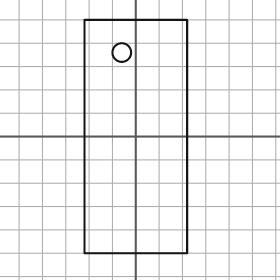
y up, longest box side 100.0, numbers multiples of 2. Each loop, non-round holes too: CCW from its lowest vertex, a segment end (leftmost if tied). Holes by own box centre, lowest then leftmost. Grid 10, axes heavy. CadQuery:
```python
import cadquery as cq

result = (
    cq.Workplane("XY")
    .moveTo(-22.0, -50.0)
    .lineTo(22.0, -50.0)
    .lineTo(22.0, 50.0)
    .lineTo(-22.0, 50.0)
    .close()
    .moveTo(-6.0, 36.0)
    .circle(4.0)
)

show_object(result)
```